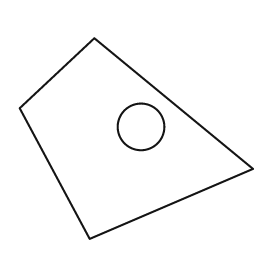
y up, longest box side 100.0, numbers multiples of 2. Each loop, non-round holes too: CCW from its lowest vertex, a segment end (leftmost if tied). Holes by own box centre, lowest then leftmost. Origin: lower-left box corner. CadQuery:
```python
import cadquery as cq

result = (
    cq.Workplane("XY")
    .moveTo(30.0, 0.0)
    .lineTo(100.0, 30.0)
    .lineTo(32.0, 86.0)
    .lineTo(0.0, 56.0)
    .close()
    .moveTo(52.0, 48.0)
    .circle(10.0)
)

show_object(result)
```